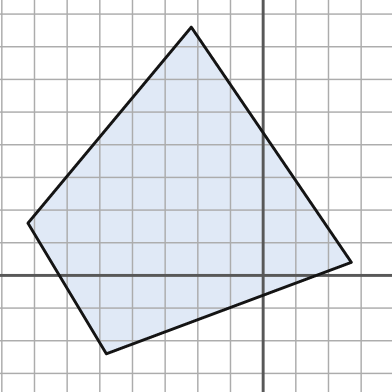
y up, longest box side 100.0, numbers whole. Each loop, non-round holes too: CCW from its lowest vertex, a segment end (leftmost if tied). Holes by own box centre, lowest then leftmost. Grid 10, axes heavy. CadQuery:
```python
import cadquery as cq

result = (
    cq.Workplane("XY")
    .moveTo(-48.0, -24.0)
    .lineTo(27.0, 4.0)
    .lineTo(-22.0, 76.0)
    .lineTo(-72.0, 16.0)
    .close()
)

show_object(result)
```